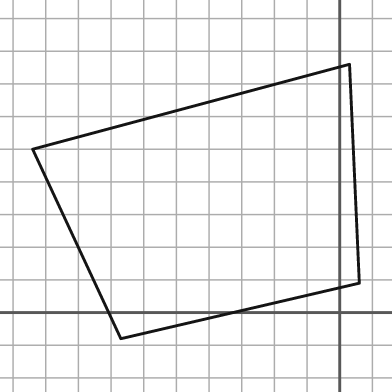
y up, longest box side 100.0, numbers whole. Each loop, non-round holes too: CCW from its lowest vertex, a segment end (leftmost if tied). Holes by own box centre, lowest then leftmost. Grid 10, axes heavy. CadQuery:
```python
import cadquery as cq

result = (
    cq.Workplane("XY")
    .moveTo(-67.0, -8.0)
    .lineTo(6.0, 9.0)
    .lineTo(3.0, 76.0)
    .lineTo(-94.0, 50.0)
    .close()
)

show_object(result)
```